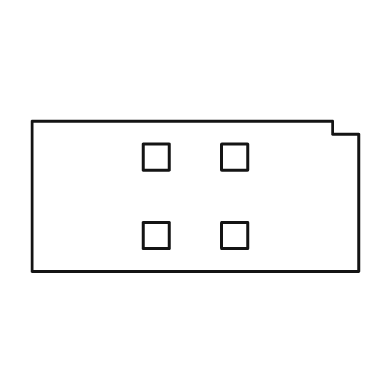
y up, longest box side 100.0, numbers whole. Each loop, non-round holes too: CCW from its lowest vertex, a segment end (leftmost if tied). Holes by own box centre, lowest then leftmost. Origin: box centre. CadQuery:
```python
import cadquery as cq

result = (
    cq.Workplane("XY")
    .moveTo(-50.0, -23.0)
    .lineTo(50.0, -23.0)
    .lineTo(50.0, 19.0)
    .lineTo(42.0, 19.0)
    .lineTo(42.0, 23.0)
    .lineTo(-50.0, 23.0)
    .close()
    .moveTo(-16.0, -16.0)
    .lineTo(-8.0, -16.0)
    .lineTo(-8.0, -8.0)
    .lineTo(-16.0, -8.0)
    .close()
    .moveTo(8.0, -16.0)
    .lineTo(16.0, -16.0)
    .lineTo(16.0, -8.0)
    .lineTo(8.0, -8.0)
    .close()
    .moveTo(-16.0, 8.0)
    .lineTo(-8.0, 8.0)
    .lineTo(-8.0, 16.0)
    .lineTo(-16.0, 16.0)
    .close()
    .moveTo(8.0, 8.0)
    .lineTo(16.0, 8.0)
    .lineTo(16.0, 16.0)
    .lineTo(8.0, 16.0)
    .close()
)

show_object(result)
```